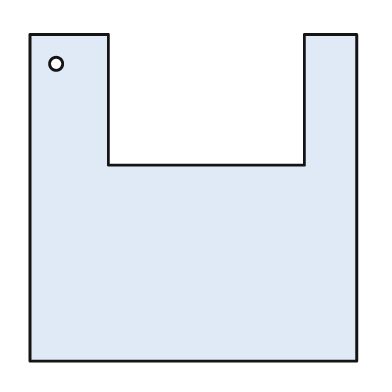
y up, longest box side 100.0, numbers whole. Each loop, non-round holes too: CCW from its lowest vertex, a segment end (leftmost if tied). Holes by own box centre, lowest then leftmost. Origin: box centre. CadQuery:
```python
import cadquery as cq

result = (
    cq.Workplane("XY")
    .moveTo(-50.0, -50.0)
    .lineTo(50.0, -50.0)
    .lineTo(50.0, 50.0)
    .lineTo(34.0, 50.0)
    .lineTo(34.0, 10.0)
    .lineTo(-26.0, 10.0)
    .lineTo(-26.0, 50.0)
    .lineTo(-50.0, 50.0)
    .close()
    .moveTo(-42.0, 41.0)
    .circle(2.0)
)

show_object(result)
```